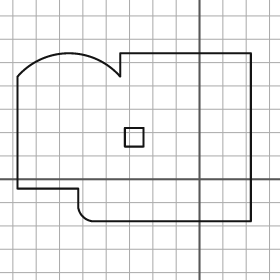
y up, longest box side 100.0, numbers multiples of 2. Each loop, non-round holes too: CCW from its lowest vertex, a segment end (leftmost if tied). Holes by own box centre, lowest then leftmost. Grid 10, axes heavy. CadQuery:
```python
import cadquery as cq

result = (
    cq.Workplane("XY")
    .moveTo(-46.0, -18.0)
    .lineTo(22.0, -18.0)
    .lineTo(22.0, 54.0)
    .lineTo(-34.0, 54.0)
    .lineTo(-34.0, 44.0)
    .threePointArc((-56.0, 54.0), (-78.0, 44.0))
    .lineTo(-78.0, -4.0)
    .lineTo(-52.0, -4.0)
    .lineTo(-52.0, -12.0)
    .threePointArc((-50.0, -16.0), (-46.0, -18.0))
    .close()
    .moveTo(-32.0, 14.0)
    .lineTo(-24.0, 14.0)
    .lineTo(-24.0, 22.0)
    .lineTo(-32.0, 22.0)
    .close()
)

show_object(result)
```